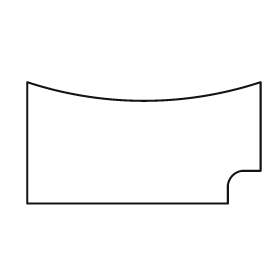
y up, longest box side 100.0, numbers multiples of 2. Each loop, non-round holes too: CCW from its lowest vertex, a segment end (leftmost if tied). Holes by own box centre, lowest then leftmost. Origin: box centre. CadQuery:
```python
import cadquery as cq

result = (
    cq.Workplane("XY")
    .moveTo(-50.0, -26.0)
    .lineTo(36.0, -26.0)
    .lineTo(36.0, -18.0)
    .threePointArc((38.0, -14.0), (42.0, -12.0))
    .lineTo(50.0, -12.0)
    .lineTo(50.0, 26.0)
    .threePointArc((0.0, 18.0), (-50.0, 26.0))
    .close()
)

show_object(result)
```